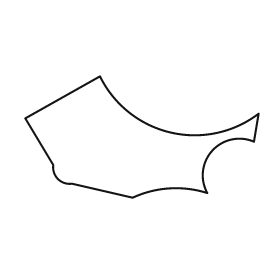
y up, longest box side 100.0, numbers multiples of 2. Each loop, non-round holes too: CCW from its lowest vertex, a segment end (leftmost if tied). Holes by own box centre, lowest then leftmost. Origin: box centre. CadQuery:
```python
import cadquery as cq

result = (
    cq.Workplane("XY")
    .moveTo(-4.0, -26.0)
    .threePointArc((12.0, -22.0), (28.0, -24.0))
    .threePointArc((30.0, -6.0), (48.0, -2.0))
    .lineTo(50.0, 10.0)
    .threePointArc((12.0, 2.0), (-18.0, 26.0))
    .lineTo(-50.0, 8.0)
    .lineTo(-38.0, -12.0)
    .threePointArc((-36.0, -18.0), (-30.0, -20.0))
    .close()
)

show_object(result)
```